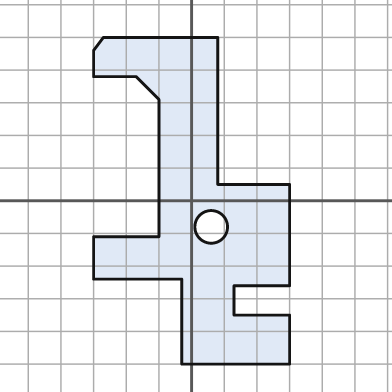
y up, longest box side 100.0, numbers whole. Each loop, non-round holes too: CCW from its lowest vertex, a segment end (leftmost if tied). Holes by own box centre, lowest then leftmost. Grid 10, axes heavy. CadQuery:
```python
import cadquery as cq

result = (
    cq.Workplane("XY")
    .moveTo(-3.0, -50.0)
    .lineTo(30.0, -50.0)
    .lineTo(30.0, -35.0)
    .lineTo(13.0, -35.0)
    .lineTo(13.0, -26.0)
    .lineTo(30.0, -26.0)
    .lineTo(30.0, 5.0)
    .lineTo(8.0, 5.0)
    .lineTo(8.0, 50.0)
    .lineTo(-27.0, 50.0)
    .lineTo(-30.0, 46.0)
    .lineTo(-30.0, 38.0)
    .lineTo(-17.0, 38.0)
    .lineTo(-10.0, 31.0)
    .lineTo(-10.0, -11.0)
    .lineTo(-30.0, -11.0)
    .lineTo(-30.0, -24.0)
    .lineTo(-3.0, -24.0)
    .close()
    .moveTo(6.0, -8.0)
    .circle(5.0)
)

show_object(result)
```